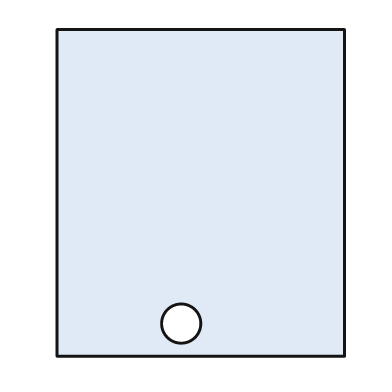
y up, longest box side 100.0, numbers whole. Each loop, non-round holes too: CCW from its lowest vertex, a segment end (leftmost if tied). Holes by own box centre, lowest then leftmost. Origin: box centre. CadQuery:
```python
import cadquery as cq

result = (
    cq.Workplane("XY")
    .moveTo(-44.0, -50.0)
    .lineTo(44.0, -50.0)
    .lineTo(44.0, 50.0)
    .lineTo(-44.0, 50.0)
    .close()
    .moveTo(-6.0, -40.0)
    .circle(6.0)
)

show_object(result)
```